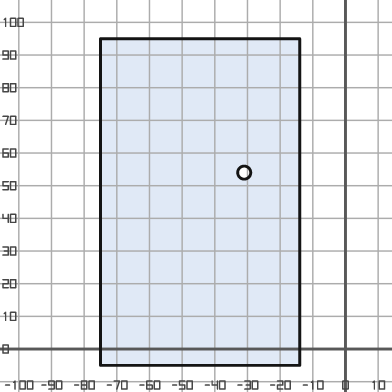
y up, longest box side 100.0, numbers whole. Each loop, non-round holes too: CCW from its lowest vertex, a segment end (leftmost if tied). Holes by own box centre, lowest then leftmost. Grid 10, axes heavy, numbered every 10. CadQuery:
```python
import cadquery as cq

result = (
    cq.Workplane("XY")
    .moveTo(-75.0, -5.0)
    .lineTo(-14.0, -5.0)
    .lineTo(-14.0, 95.0)
    .lineTo(-75.0, 95.0)
    .close()
    .moveTo(-31.0, 54.0)
    .circle(2.0)
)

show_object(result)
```